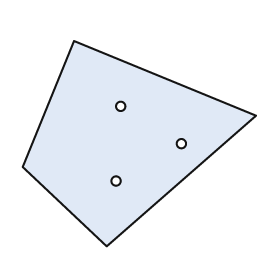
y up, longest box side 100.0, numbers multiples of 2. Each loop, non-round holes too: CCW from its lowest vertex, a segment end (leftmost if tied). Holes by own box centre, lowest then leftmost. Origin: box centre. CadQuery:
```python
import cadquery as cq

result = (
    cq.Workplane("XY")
    .moveTo(-14.0, -44.0)
    .lineTo(50.0, 12.0)
    .lineTo(-28.0, 44.0)
    .lineTo(-50.0, -10.0)
    .close()
    .moveTo(-10.0, -16.0)
    .circle(2.0)
    .moveTo(18.0, 0.0)
    .circle(2.0)
    .moveTo(-8.0, 16.0)
    .circle(2.0)
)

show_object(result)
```